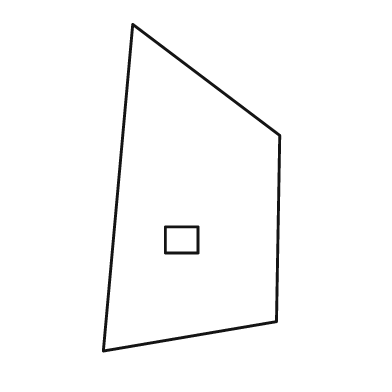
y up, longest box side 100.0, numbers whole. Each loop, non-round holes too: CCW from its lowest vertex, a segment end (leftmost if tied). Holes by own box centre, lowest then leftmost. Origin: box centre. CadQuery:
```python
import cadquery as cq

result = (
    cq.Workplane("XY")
    .moveTo(-27.0, -50.0)
    .lineTo(26.0, -41.0)
    .lineTo(27.0, 16.0)
    .lineTo(-18.0, 50.0)
    .close()
    .moveTo(-8.0, -20.0)
    .lineTo(2.0, -20.0)
    .lineTo(2.0, -12.0)
    .lineTo(-8.0, -12.0)
    .close()
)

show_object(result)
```